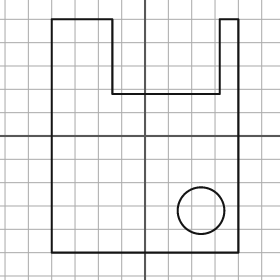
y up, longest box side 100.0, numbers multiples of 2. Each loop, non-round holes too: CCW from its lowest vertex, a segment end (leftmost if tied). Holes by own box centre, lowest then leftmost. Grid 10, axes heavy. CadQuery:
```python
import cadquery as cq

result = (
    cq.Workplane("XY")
    .moveTo(-40.0, -50.0)
    .lineTo(40.0, -50.0)
    .lineTo(40.0, 50.0)
    .lineTo(32.0, 50.0)
    .lineTo(32.0, 18.0)
    .lineTo(-14.0, 18.0)
    .lineTo(-14.0, 50.0)
    .lineTo(-40.0, 50.0)
    .close()
    .moveTo(24.0, -32.0)
    .circle(10.0)
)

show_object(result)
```